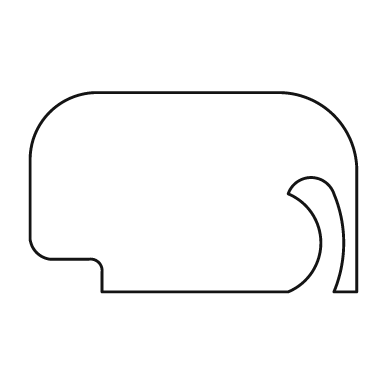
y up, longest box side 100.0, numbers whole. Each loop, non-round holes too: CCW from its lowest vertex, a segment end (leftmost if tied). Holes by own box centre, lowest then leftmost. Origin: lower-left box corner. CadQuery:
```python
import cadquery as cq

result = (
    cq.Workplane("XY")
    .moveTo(22.0, 0.0)
    .lineTo(79.0, 0.0)
    .threePointArc((89.0, 15.0), (79.0, 30.0))
    .threePointArc((86.0, 35.0), (93.0, 30.0))
    .threePointArc((96.0, 15.0), (93.0, 0.0))
    .lineTo(100.0, 0.0)
    .lineTo(100.0, 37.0)
    .threePointArc((93.0, 54.0), (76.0, 61.0))
    .lineTo(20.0, 61.0)
    .threePointArc((6.0, 55.0), (0.0, 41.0))
    .lineTo(0.0, 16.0)
    .threePointArc((2.0, 12.0), (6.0, 10.0))
    .lineTo(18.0, 10.0)
    .threePointArc((21.0, 9.0), (22.0, 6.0))
    .close()
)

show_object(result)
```